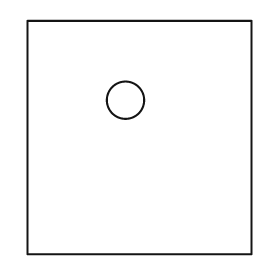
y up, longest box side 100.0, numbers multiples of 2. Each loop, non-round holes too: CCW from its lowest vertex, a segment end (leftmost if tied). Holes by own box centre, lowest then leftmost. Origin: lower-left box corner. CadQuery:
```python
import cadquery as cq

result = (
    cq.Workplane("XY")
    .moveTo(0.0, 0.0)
    .lineTo(96.0, 0.0)
    .lineTo(96.0, 100.0)
    .lineTo(0.0, 100.0)
    .close()
    .moveTo(42.0, 66.0)
    .circle(8.0)
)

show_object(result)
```